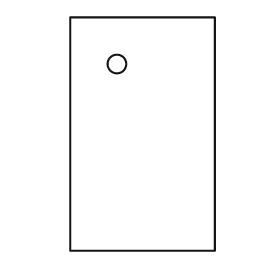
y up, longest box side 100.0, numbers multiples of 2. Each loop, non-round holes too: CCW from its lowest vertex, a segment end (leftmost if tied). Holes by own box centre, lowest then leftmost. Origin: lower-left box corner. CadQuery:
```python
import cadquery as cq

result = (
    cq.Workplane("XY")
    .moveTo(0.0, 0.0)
    .lineTo(62.0, 0.0)
    .lineTo(62.0, 100.0)
    .lineTo(0.0, 100.0)
    .close()
    .moveTo(20.0, 80.0)
    .circle(4.0)
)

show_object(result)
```